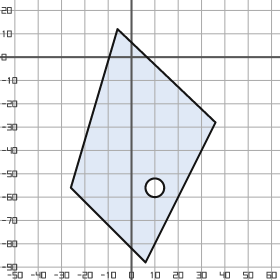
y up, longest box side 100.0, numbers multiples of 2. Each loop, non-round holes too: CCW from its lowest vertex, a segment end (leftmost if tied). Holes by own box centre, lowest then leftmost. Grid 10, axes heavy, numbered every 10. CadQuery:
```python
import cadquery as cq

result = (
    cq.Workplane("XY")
    .moveTo(6.0, -88.0)
    .lineTo(36.0, -28.0)
    .lineTo(-6.0, 12.0)
    .lineTo(-26.0, -56.0)
    .close()
    .moveTo(10.0, -56.0)
    .circle(4.0)
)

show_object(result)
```